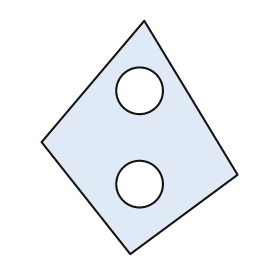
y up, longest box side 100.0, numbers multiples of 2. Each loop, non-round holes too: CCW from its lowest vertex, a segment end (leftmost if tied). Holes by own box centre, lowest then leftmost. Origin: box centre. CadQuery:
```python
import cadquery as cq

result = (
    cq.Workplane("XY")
    .moveTo(-4.0, -50.0)
    .lineTo(42.0, -16.0)
    .lineTo(2.0, 50.0)
    .lineTo(-42.0, -2.0)
    .close()
    .moveTo(0.0, -20.0)
    .circle(10.0)
    .moveTo(0.0, 20.0)
    .circle(10.0)
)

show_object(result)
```